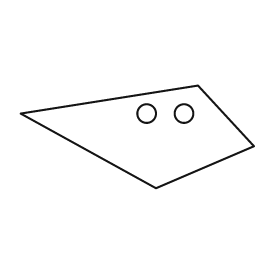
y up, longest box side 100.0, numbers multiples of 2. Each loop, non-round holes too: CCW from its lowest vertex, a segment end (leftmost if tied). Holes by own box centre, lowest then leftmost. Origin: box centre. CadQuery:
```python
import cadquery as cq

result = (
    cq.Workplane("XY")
    .moveTo(8.0, -22.0)
    .lineTo(50.0, -4.0)
    .lineTo(26.0, 22.0)
    .lineTo(-50.0, 10.0)
    .close()
    .moveTo(4.0, 10.0)
    .circle(4.0)
    .moveTo(20.0, 10.0)
    .circle(4.0)
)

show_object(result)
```